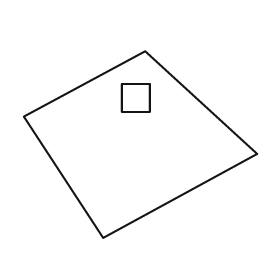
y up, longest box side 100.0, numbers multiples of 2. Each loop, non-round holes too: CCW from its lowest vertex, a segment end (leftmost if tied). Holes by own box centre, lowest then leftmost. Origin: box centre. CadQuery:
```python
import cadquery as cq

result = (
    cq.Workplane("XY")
    .moveTo(-16.0, -40.0)
    .lineTo(50.0, -4.0)
    .lineTo(2.0, 40.0)
    .lineTo(-50.0, 12.0)
    .close()
    .moveTo(-8.0, 14.0)
    .lineTo(4.0, 14.0)
    .lineTo(4.0, 26.0)
    .lineTo(-8.0, 26.0)
    .close()
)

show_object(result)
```